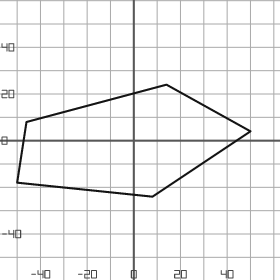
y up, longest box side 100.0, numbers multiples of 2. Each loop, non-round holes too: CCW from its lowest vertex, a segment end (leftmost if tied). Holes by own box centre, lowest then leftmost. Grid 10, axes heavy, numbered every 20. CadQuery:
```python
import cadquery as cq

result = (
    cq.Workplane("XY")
    .moveTo(8.0, -24.0)
    .lineTo(50.0, 4.0)
    .lineTo(14.0, 24.0)
    .lineTo(-46.0, 8.0)
    .lineTo(-50.0, -18.0)
    .close()
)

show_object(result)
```